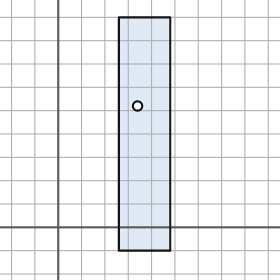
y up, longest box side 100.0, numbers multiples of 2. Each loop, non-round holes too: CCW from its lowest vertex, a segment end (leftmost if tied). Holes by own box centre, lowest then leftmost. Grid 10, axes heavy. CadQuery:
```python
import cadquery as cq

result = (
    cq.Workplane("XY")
    .moveTo(26.0, -10.0)
    .lineTo(48.0, -10.0)
    .lineTo(48.0, 90.0)
    .lineTo(26.0, 90.0)
    .close()
    .moveTo(34.0, 52.0)
    .circle(2.0)
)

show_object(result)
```